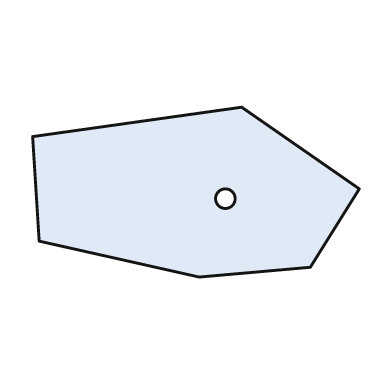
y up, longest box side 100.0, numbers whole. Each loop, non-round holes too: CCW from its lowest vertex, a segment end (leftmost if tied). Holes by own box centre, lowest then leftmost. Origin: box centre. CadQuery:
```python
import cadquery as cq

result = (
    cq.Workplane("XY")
    .moveTo(1.0, -26.0)
    .lineTo(35.0, -23.0)
    .lineTo(50.0, 1.0)
    .lineTo(14.0, 26.0)
    .lineTo(-50.0, 17.0)
    .lineTo(-48.0, -15.0)
    .close()
    .moveTo(9.0, -2.0)
    .circle(3.0)
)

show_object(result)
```